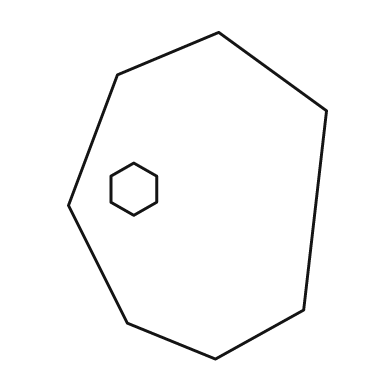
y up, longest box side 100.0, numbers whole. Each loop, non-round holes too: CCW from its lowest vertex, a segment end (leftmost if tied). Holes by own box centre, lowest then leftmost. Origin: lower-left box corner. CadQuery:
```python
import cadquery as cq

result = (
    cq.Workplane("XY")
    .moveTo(45.0, 0.0)
    .lineTo(72.0, 15.0)
    .lineTo(79.0, 76.0)
    .lineTo(46.0, 100.0)
    .lineTo(15.0, 87.0)
    .lineTo(0.0, 47.0)
    .lineTo(18.0, 11.0)
    .close()
    .moveTo(20.0, 44.0)
    .lineTo(27.0, 48.0)
    .lineTo(27.0, 56.0)
    .lineTo(20.0, 60.0)
    .lineTo(13.0, 56.0)
    .lineTo(13.0, 48.0)
    .close()
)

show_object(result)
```